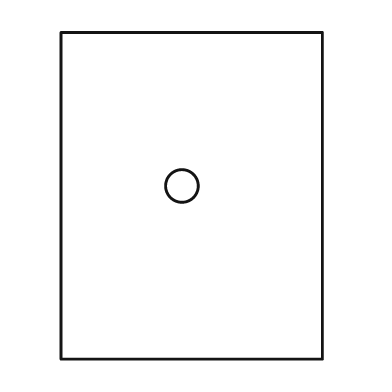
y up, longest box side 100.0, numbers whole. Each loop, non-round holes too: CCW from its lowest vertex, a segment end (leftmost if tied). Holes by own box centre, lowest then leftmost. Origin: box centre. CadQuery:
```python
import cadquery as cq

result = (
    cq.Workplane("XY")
    .moveTo(-40.0, -50.0)
    .lineTo(40.0, -50.0)
    .lineTo(40.0, 50.0)
    .lineTo(-40.0, 50.0)
    .close()
    .moveTo(-3.0, 3.0)
    .circle(5.0)
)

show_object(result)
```